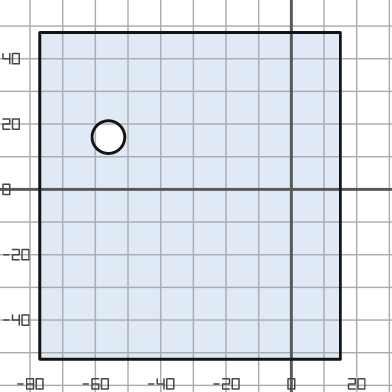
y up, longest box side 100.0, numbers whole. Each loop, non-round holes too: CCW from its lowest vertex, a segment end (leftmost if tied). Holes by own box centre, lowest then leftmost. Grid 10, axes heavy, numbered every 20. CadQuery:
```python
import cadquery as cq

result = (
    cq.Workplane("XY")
    .moveTo(-77.0, -52.0)
    .lineTo(15.0, -52.0)
    .lineTo(15.0, 48.0)
    .lineTo(-77.0, 48.0)
    .close()
    .moveTo(-56.0, 16.0)
    .circle(5.0)
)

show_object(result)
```